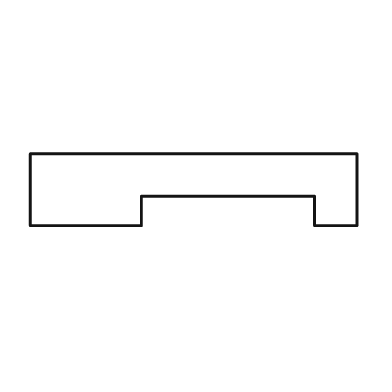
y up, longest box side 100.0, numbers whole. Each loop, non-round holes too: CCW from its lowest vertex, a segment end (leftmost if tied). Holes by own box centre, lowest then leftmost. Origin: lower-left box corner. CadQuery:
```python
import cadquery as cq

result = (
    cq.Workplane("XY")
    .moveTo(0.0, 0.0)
    .lineTo(34.0, 0.0)
    .lineTo(34.0, 9.0)
    .lineTo(87.0, 9.0)
    .lineTo(87.0, 0.0)
    .lineTo(100.0, 0.0)
    .lineTo(100.0, 22.0)
    .lineTo(0.0, 22.0)
    .close()
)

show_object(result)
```